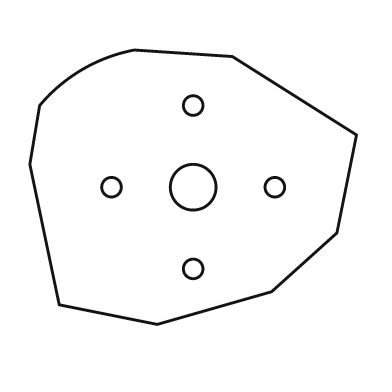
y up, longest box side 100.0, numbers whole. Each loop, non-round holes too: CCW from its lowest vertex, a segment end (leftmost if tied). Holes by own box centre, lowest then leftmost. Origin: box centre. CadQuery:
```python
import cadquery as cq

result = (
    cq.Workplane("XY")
    .moveTo(-11.0, -42.0)
    .lineTo(24.0, -32.0)
    .lineTo(44.0, -14.0)
    .lineTo(50.0, 16.0)
    .lineTo(12.0, 40.0)
    .lineTo(-18.0, 42.0)
    .threePointArc((-34.0, 36.0), (-47.0, 25.0))
    .lineTo(-50.0, 7.0)
    .lineTo(-41.0, -36.0)
    .close()
    .moveTo(0.0, -25.0)
    .circle(3.0)
    .moveTo(-25.0, 0.0)
    .circle(3.0)
    .moveTo(0.0, 0.0)
    .circle(7.0)
    .moveTo(25.0, 0.0)
    .circle(3.0)
    .moveTo(0.0, 25.0)
    .circle(3.0)
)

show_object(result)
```